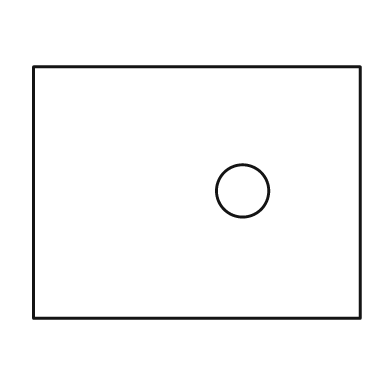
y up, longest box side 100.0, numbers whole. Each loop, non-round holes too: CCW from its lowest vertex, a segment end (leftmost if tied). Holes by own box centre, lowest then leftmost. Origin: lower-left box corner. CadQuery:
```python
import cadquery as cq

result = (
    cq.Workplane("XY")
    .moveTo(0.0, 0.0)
    .lineTo(100.0, 0.0)
    .lineTo(100.0, 77.0)
    .lineTo(0.0, 77.0)
    .close()
    .moveTo(64.0, 39.0)
    .circle(8.0)
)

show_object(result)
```